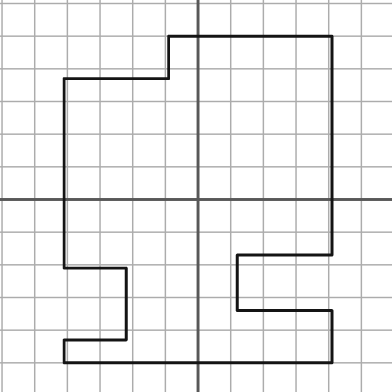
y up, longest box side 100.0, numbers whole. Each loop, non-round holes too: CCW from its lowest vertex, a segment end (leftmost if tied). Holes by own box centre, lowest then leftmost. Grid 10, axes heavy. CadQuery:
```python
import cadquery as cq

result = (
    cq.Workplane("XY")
    .moveTo(-41.0, -50.0)
    .lineTo(41.0, -50.0)
    .lineTo(41.0, -34.0)
    .lineTo(12.0, -34.0)
    .lineTo(12.0, -17.0)
    .lineTo(41.0, -17.0)
    .lineTo(41.0, 50.0)
    .lineTo(-9.0, 50.0)
    .lineTo(-9.0, 37.0)
    .lineTo(-41.0, 37.0)
    .lineTo(-41.0, -21.0)
    .lineTo(-22.0, -21.0)
    .lineTo(-22.0, -43.0)
    .lineTo(-41.0, -43.0)
    .close()
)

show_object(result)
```